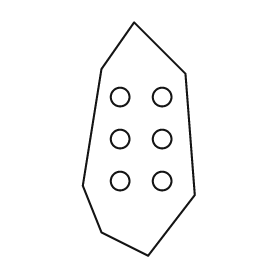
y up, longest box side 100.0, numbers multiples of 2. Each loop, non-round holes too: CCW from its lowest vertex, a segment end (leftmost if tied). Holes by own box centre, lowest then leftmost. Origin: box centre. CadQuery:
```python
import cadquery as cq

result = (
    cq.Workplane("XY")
    .moveTo(4.0, -50.0)
    .lineTo(24.0, -24.0)
    .lineTo(20.0, 28.0)
    .lineTo(-2.0, 50.0)
    .lineTo(-16.0, 30.0)
    .lineTo(-24.0, -20.0)
    .lineTo(-16.0, -40.0)
    .close()
    .moveTo(-8.0, -18.0)
    .circle(4.0)
    .moveTo(10.0, -18.0)
    .circle(4.0)
    .moveTo(-8.0, 0.0)
    .circle(4.0)
    .moveTo(10.0, 0.0)
    .circle(4.0)
    .moveTo(-8.0, 18.0)
    .circle(4.0)
    .moveTo(10.0, 18.0)
    .circle(4.0)
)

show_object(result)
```